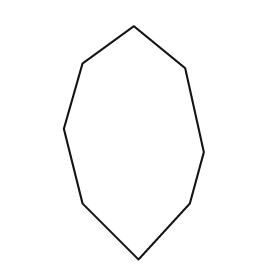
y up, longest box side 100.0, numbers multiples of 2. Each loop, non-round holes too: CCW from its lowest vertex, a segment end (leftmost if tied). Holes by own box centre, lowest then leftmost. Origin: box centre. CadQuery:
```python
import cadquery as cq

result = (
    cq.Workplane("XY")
    .moveTo(2.0, -50.0)
    .lineTo(24.0, -26.0)
    .lineTo(30.0, -4.0)
    .lineTo(22.0, 32.0)
    .lineTo(0.0, 50.0)
    .lineTo(-22.0, 34.0)
    .lineTo(-30.0, 6.0)
    .lineTo(-22.0, -26.0)
    .close()
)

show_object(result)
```